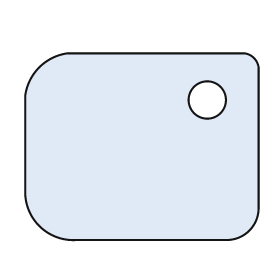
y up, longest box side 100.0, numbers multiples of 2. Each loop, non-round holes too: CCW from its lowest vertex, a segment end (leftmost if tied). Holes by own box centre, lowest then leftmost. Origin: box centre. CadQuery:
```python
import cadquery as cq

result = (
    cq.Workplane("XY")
    .moveTo(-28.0, -40.0)
    .lineTo(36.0, -40.0)
    .threePointArc((46.0, -36.0), (50.0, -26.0))
    .lineTo(50.0, 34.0)
    .threePointArc((48.0, 38.0), (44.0, 40.0))
    .lineTo(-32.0, 40.0)
    .threePointArc((-44.0, 34.0), (-50.0, 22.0))
    .lineTo(-50.0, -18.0)
    .threePointArc((-44.0, -34.0), (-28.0, -40.0))
    .close()
    .moveTo(28.0, 20.0)
    .circle(8.0)
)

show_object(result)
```